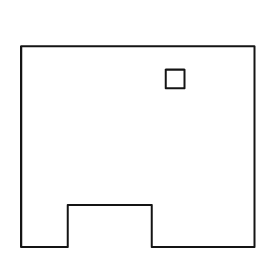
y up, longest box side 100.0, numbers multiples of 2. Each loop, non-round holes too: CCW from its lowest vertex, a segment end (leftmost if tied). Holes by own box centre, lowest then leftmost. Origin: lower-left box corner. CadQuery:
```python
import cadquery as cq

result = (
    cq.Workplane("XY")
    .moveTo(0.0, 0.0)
    .lineTo(20.0, 0.0)
    .lineTo(20.0, 18.0)
    .lineTo(56.0, 18.0)
    .lineTo(56.0, 0.0)
    .lineTo(100.0, 0.0)
    .lineTo(100.0, 86.0)
    .lineTo(0.0, 86.0)
    .close()
    .moveTo(62.0, 68.0)
    .lineTo(70.0, 68.0)
    .lineTo(70.0, 76.0)
    .lineTo(62.0, 76.0)
    .close()
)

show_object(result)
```